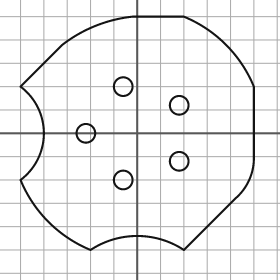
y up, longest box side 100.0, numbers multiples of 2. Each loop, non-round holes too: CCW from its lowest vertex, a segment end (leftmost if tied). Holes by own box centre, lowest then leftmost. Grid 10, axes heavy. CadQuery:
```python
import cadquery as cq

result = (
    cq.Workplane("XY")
    .moveTo(-20.0, -50.0)
    .threePointArc((0.0, -44.0), (20.0, -50.0))
    .lineTo(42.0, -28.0)
    .threePointArc((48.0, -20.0), (50.0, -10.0))
    .lineTo(50.0, 20.0)
    .threePointArc((38.0, 38.0), (20.0, 50.0))
    .lineTo(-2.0, 50.0)
    .threePointArc((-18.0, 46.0), (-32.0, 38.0))
    .lineTo(-50.0, 20.0)
    .threePointArc((-40.0, 0.0), (-50.0, -20.0))
    .threePointArc((-38.0, -38.0), (-20.0, -50.0))
    .close()
    .moveTo(-6.0, -20.0)
    .circle(4.0)
    .moveTo(18.0, -12.0)
    .circle(4.0)
    .moveTo(-22.0, 0.0)
    .circle(4.0)
    .moveTo(18.0, 12.0)
    .circle(4.0)
    .moveTo(-6.0, 20.0)
    .circle(4.0)
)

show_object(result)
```